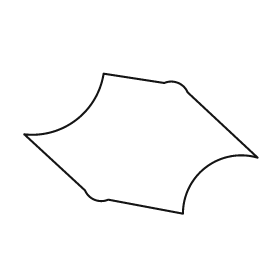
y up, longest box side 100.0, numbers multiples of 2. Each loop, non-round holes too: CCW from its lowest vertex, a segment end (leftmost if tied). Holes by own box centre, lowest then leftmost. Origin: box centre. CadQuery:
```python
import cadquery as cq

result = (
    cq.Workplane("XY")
    .moveTo(18.0, -30.0)
    .threePointArc((28.0, -10.0), (50.0, -6.0))
    .lineTo(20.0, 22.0)
    .threePointArc((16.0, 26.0), (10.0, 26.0))
    .lineTo(-16.0, 30.0)
    .threePointArc((-28.0, 10.0), (-50.0, 4.0))
    .lineTo(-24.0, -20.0)
    .threePointArc((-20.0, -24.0), (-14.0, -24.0))
    .close()
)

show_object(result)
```